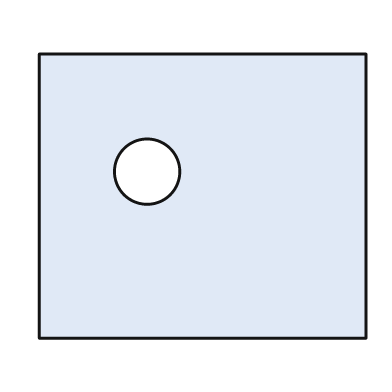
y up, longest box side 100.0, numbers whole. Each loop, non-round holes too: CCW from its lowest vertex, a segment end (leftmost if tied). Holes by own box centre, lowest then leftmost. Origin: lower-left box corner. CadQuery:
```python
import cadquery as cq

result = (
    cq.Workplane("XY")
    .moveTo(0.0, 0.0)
    .lineTo(100.0, 0.0)
    .lineTo(100.0, 87.0)
    .lineTo(0.0, 87.0)
    .close()
    .moveTo(33.0, 51.0)
    .circle(10.0)
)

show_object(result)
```